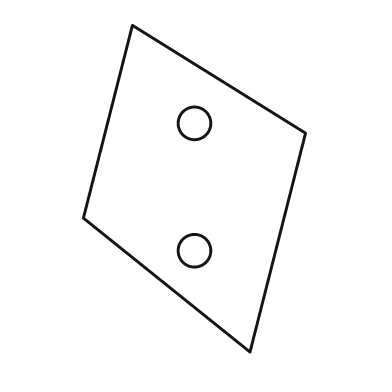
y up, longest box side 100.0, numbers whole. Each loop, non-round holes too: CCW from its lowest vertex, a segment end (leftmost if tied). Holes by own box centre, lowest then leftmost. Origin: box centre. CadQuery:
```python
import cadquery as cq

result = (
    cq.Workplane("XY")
    .moveTo(17.0, -50.0)
    .lineTo(34.0, 17.0)
    .lineTo(-19.0, 50.0)
    .lineTo(-34.0, -9.0)
    .close()
    .moveTo(0.0, -19.0)
    .circle(5.0)
    .moveTo(0.0, 20.0)
    .circle(5.0)
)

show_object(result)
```